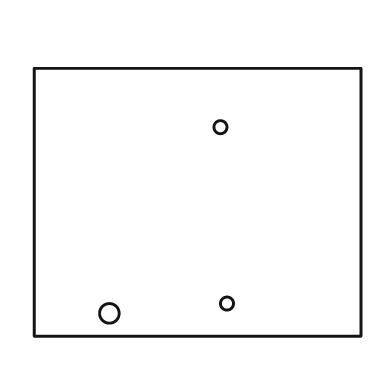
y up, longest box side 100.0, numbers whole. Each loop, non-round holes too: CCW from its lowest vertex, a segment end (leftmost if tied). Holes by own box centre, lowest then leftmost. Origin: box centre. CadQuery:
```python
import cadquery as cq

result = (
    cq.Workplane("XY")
    .moveTo(-50.0, -41.0)
    .lineTo(50.0, -41.0)
    .lineTo(50.0, 41.0)
    .lineTo(-50.0, 41.0)
    .close()
    .moveTo(-27.0, -34.0)
    .circle(3.0)
    .moveTo(9.0, -31.0)
    .circle(2.0)
    .moveTo(7.0, 23.0)
    .circle(2.0)
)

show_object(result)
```